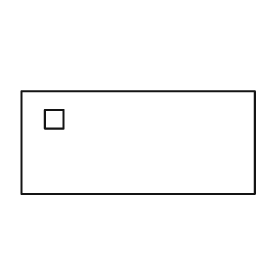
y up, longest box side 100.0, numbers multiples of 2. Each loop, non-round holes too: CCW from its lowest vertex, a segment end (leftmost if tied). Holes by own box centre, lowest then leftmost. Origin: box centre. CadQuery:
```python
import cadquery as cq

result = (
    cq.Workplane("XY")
    .moveTo(-50.0, -22.0)
    .lineTo(50.0, -22.0)
    .lineTo(50.0, 22.0)
    .lineTo(-50.0, 22.0)
    .close()
    .moveTo(-40.0, 6.0)
    .lineTo(-32.0, 6.0)
    .lineTo(-32.0, 14.0)
    .lineTo(-40.0, 14.0)
    .close()
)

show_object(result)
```